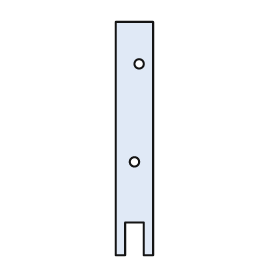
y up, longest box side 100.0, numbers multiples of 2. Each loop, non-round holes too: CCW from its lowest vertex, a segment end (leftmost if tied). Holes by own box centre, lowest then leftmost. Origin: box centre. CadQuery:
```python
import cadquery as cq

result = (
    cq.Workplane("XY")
    .moveTo(-8.0, -50.0)
    .lineTo(-4.0, -50.0)
    .lineTo(-4.0, -36.0)
    .lineTo(4.0, -36.0)
    .lineTo(4.0, -50.0)
    .lineTo(8.0, -50.0)
    .lineTo(8.0, 50.0)
    .lineTo(-8.0, 50.0)
    .close()
    .moveTo(0.0, -10.0)
    .circle(2.0)
    .moveTo(2.0, 32.0)
    .circle(2.0)
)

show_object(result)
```